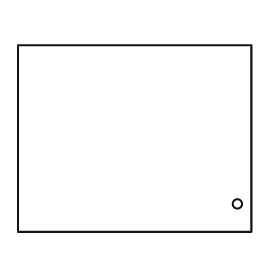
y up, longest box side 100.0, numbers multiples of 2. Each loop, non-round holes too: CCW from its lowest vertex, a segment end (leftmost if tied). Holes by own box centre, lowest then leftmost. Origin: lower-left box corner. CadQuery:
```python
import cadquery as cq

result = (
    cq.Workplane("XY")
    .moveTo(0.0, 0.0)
    .lineTo(100.0, 0.0)
    .lineTo(100.0, 80.0)
    .lineTo(0.0, 80.0)
    .close()
    .moveTo(94.0, 12.0)
    .circle(2.0)
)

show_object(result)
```